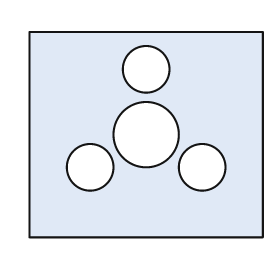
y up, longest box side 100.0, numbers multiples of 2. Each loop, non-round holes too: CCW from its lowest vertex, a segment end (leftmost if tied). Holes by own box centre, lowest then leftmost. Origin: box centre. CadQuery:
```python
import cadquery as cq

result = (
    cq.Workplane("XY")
    .moveTo(-50.0, -44.0)
    .lineTo(50.0, -44.0)
    .lineTo(50.0, 44.0)
    .lineTo(-50.0, 44.0)
    .close()
    .moveTo(-24.0, -14.0)
    .circle(10.0)
    .moveTo(24.0, -14.0)
    .circle(10.0)
    .moveTo(0.0, 0.0)
    .circle(14.0)
    .moveTo(0.0, 28.0)
    .circle(10.0)
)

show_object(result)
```